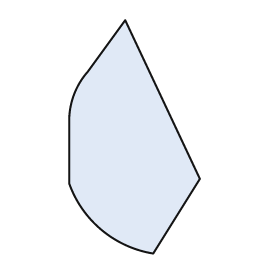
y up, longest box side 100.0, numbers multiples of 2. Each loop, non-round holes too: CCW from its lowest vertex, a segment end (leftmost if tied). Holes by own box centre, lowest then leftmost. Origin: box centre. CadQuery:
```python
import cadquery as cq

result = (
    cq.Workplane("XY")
    .moveTo(8.0, -50.0)
    .lineTo(28.0, -18.0)
    .lineTo(-4.0, 50.0)
    .lineTo(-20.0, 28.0)
    .threePointArc((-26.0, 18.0), (-28.0, 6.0))
    .lineTo(-28.0, -20.0)
    .threePointArc((-14.0, -40.0), (8.0, -50.0))
    .close()
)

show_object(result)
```